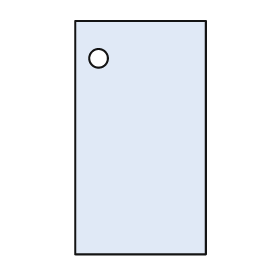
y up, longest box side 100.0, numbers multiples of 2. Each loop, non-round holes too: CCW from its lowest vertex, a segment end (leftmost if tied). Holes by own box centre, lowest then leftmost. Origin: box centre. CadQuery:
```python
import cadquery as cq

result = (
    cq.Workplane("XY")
    .moveTo(-28.0, -50.0)
    .lineTo(28.0, -50.0)
    .lineTo(28.0, 50.0)
    .lineTo(-28.0, 50.0)
    .close()
    .moveTo(-18.0, 34.0)
    .circle(4.0)
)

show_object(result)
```